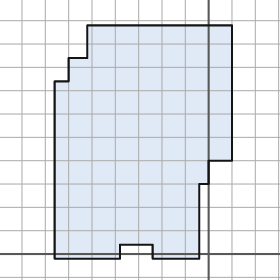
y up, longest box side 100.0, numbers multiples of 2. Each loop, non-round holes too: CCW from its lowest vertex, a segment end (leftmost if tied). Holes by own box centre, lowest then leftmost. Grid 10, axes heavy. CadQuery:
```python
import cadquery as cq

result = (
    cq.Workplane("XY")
    .moveTo(-66.0, -2.0)
    .lineTo(-38.0, -2.0)
    .lineTo(-38.0, 4.0)
    .lineTo(-24.0, 4.0)
    .lineTo(-24.0, -2.0)
    .lineTo(-4.0, -2.0)
    .lineTo(-4.0, 30.0)
    .lineTo(0.0, 30.0)
    .lineTo(0.0, 40.0)
    .lineTo(10.0, 40.0)
    .lineTo(10.0, 98.0)
    .lineTo(-52.0, 98.0)
    .lineTo(-52.0, 84.0)
    .lineTo(-60.0, 84.0)
    .lineTo(-60.0, 74.0)
    .lineTo(-66.0, 74.0)
    .close()
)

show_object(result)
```